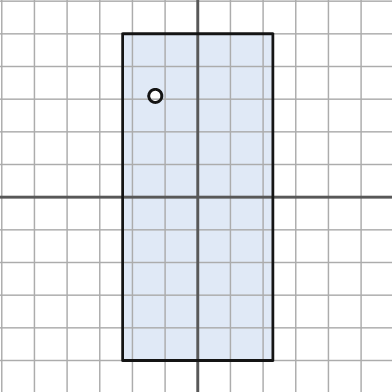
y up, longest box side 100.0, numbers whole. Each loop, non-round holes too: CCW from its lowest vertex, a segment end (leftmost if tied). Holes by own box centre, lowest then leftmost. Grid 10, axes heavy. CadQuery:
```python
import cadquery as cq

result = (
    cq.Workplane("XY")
    .moveTo(-23.0, -50.0)
    .lineTo(23.0, -50.0)
    .lineTo(23.0, 50.0)
    .lineTo(-23.0, 50.0)
    .close()
    .moveTo(-13.0, 31.0)
    .circle(2.0)
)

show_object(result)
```